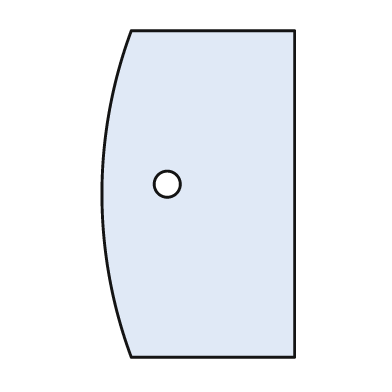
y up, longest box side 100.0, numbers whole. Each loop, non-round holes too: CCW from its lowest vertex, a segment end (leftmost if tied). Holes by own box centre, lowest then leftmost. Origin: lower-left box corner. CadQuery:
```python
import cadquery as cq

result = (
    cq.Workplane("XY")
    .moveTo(9.0, 0.0)
    .lineTo(59.0, 0.0)
    .lineTo(59.0, 100.0)
    .lineTo(9.0, 100.0)
    .threePointArc((0.0, 50.0), (9.0, 0.0))
    .close()
    .moveTo(20.0, 53.0)
    .circle(4.0)
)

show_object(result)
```